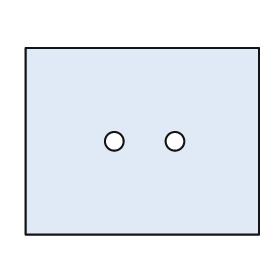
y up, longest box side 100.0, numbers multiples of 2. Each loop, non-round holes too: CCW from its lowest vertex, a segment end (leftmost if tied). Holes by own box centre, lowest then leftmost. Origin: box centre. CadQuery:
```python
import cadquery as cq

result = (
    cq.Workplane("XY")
    .moveTo(-50.0, -40.0)
    .lineTo(50.0, -40.0)
    .lineTo(50.0, 40.0)
    .lineTo(-50.0, 40.0)
    .close()
    .moveTo(-12.0, 0.0)
    .circle(4.0)
    .moveTo(14.0, 0.0)
    .circle(4.0)
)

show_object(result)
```